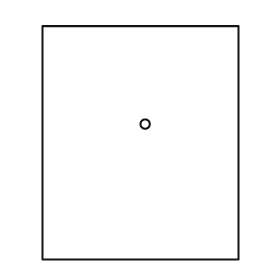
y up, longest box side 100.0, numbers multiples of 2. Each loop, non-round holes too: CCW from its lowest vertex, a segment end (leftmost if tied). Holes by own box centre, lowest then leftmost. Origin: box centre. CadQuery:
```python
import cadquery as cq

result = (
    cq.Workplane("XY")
    .moveTo(-42.0, -50.0)
    .lineTo(42.0, -50.0)
    .lineTo(42.0, 50.0)
    .lineTo(-42.0, 50.0)
    .close()
    .moveTo(2.0, 8.0)
    .circle(2.0)
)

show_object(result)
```